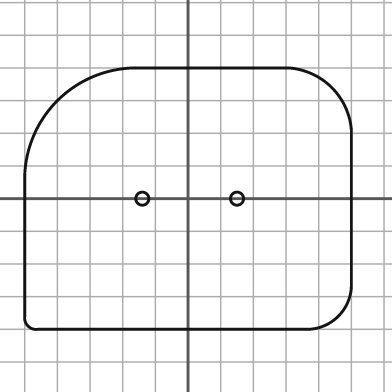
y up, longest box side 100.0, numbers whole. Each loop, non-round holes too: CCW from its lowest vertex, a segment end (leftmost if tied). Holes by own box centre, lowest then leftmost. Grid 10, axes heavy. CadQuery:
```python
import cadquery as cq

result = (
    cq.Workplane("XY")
    .moveTo(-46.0, -40.0)
    .lineTo(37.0, -40.0)
    .threePointArc((46.0, -36.0), (50.0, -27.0))
    .lineTo(50.0, 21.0)
    .threePointArc((44.0, 34.0), (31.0, 40.0))
    .lineTo(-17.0, 40.0)
    .threePointArc((-40.0, 30.0), (-50.0, 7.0))
    .lineTo(-50.0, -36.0)
    .threePointArc((-49.0, -39.0), (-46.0, -40.0))
    .close()
    .moveTo(-14.0, 0.0)
    .circle(2.0)
    .moveTo(15.0, 0.0)
    .circle(2.0)
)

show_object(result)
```